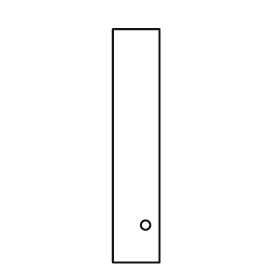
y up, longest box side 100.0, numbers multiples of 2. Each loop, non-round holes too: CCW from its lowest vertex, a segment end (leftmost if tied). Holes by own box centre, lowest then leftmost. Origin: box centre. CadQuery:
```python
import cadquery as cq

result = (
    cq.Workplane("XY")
    .moveTo(-10.0, -50.0)
    .lineTo(10.0, -50.0)
    .lineTo(10.0, 50.0)
    .lineTo(-10.0, 50.0)
    .close()
    .moveTo(4.0, -34.0)
    .circle(2.0)
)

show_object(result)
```